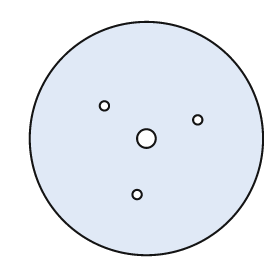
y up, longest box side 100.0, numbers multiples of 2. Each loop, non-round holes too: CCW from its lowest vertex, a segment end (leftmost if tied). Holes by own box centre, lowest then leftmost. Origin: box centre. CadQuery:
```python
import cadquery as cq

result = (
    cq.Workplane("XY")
    .moveTo(0.0, 0.0)
    .circle(50.0)
    .moveTo(-4.0, -24.0)
    .circle(2.0)
    .moveTo(0.0, 0.0)
    .circle(4.0)
    .moveTo(22.0, 8.0)
    .circle(2.0)
    .moveTo(-18.0, 14.0)
    .circle(2.0)
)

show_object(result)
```